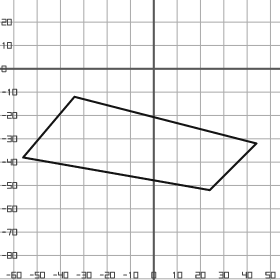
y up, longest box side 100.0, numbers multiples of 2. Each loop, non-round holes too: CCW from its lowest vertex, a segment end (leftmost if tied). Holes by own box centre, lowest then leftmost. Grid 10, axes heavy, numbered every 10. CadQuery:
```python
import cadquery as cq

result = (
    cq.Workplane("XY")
    .moveTo(24.0, -52.0)
    .lineTo(44.0, -32.0)
    .lineTo(-34.0, -12.0)
    .lineTo(-56.0, -38.0)
    .close()
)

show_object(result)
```